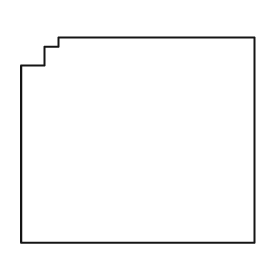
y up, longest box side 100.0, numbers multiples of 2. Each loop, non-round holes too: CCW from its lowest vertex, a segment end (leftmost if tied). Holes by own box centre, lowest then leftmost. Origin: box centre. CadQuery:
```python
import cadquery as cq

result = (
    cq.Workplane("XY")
    .moveTo(-50.0, -44.0)
    .lineTo(50.0, -44.0)
    .lineTo(50.0, 44.0)
    .lineTo(-34.0, 44.0)
    .lineTo(-34.0, 40.0)
    .lineTo(-40.0, 40.0)
    .lineTo(-40.0, 32.0)
    .lineTo(-50.0, 32.0)
    .close()
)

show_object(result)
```